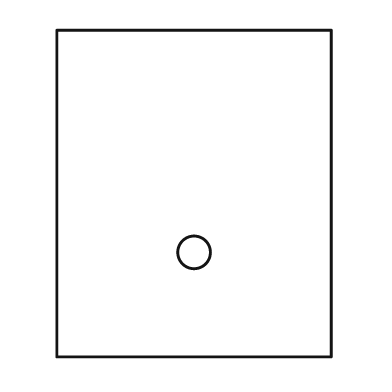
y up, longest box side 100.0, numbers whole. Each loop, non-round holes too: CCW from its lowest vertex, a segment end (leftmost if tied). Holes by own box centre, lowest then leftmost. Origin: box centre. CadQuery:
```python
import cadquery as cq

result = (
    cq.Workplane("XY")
    .moveTo(-42.0, -50.0)
    .lineTo(42.0, -50.0)
    .lineTo(42.0, 50.0)
    .lineTo(-42.0, 50.0)
    .close()
    .moveTo(0.0, -18.0)
    .circle(5.0)
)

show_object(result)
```